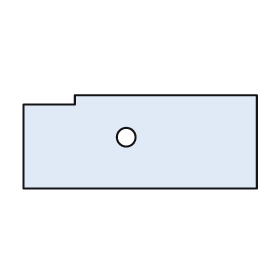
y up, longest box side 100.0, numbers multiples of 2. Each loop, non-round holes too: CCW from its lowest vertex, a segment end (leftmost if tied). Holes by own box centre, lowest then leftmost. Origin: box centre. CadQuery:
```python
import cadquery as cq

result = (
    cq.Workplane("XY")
    .moveTo(-50.0, -20.0)
    .lineTo(50.0, -20.0)
    .lineTo(50.0, 20.0)
    .lineTo(-28.0, 20.0)
    .lineTo(-28.0, 16.0)
    .lineTo(-50.0, 16.0)
    .close()
    .moveTo(-6.0, 2.0)
    .circle(4.0)
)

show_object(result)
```